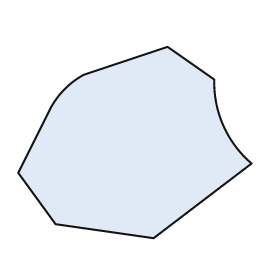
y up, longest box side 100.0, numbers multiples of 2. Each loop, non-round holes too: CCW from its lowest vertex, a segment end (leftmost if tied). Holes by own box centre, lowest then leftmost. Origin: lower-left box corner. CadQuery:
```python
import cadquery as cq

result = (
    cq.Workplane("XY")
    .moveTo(58.0, 0.0)
    .lineTo(100.0, 32.0)
    .threePointArc((88.0, 48.0), (84.0, 68.0))
    .lineTo(64.0, 82.0)
    .lineTo(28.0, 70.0)
    .threePointArc((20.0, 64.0), (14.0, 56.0))
    .lineTo(0.0, 28.0)
    .lineTo(16.0, 6.0)
    .close()
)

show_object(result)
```